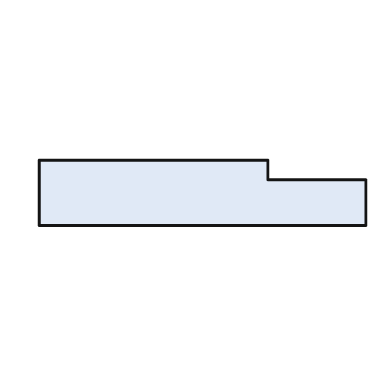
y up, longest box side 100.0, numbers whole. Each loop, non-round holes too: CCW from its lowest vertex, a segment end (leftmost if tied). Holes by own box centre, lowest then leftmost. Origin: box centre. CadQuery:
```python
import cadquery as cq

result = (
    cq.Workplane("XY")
    .moveTo(-50.0, -10.0)
    .lineTo(50.0, -10.0)
    .lineTo(50.0, 4.0)
    .lineTo(20.0, 4.0)
    .lineTo(20.0, 10.0)
    .lineTo(-50.0, 10.0)
    .close()
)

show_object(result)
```